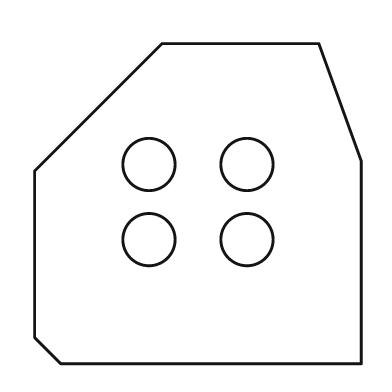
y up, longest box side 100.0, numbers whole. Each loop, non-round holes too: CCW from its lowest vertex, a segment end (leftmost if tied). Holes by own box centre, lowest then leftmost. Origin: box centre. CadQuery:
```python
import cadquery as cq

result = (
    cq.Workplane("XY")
    .moveTo(-42.0, -49.0)
    .lineTo(50.0, -49.0)
    .lineTo(50.0, 13.0)
    .lineTo(37.0, 49.0)
    .lineTo(-11.0, 49.0)
    .lineTo(-50.0, 10.0)
    .lineTo(-50.0, -41.0)
    .close()
    .moveTo(-15.0, -11.0)
    .circle(8.0)
    .moveTo(15.0, -11.0)
    .circle(8.0)
    .moveTo(-15.0, 12.0)
    .circle(8.0)
    .moveTo(15.0, 12.0)
    .circle(8.0)
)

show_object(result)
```